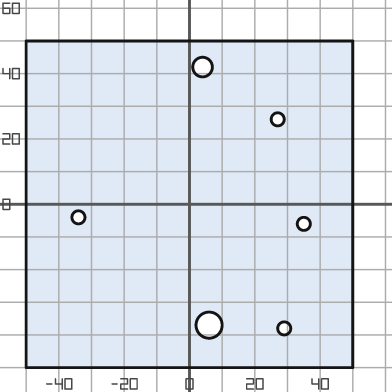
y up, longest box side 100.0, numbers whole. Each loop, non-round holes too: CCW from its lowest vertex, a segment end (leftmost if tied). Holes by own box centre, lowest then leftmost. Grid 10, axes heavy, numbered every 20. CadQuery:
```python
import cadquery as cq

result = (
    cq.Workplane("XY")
    .moveTo(-50.0, -50.0)
    .lineTo(50.0, -50.0)
    .lineTo(50.0, 50.0)
    .lineTo(-50.0, 50.0)
    .close()
    .moveTo(29.0, -38.0)
    .circle(2.0)
    .moveTo(6.0, -37.0)
    .circle(4.0)
    .moveTo(35.0, -6.0)
    .circle(2.0)
    .moveTo(-34.0, -4.0)
    .circle(2.0)
    .moveTo(27.0, 26.0)
    .circle(2.0)
    .moveTo(4.0, 42.0)
    .circle(3.0)
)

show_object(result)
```